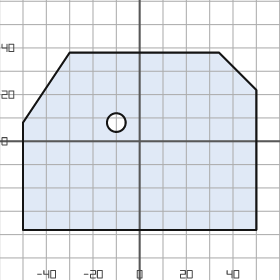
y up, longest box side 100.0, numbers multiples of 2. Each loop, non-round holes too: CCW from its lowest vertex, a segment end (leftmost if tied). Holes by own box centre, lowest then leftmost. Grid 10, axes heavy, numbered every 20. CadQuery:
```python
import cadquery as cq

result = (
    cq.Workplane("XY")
    .moveTo(-50.0, -38.0)
    .lineTo(50.0, -38.0)
    .lineTo(50.0, 22.0)
    .lineTo(34.0, 38.0)
    .lineTo(-30.0, 38.0)
    .lineTo(-50.0, 8.0)
    .close()
    .moveTo(-10.0, 8.0)
    .circle(4.0)
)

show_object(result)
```